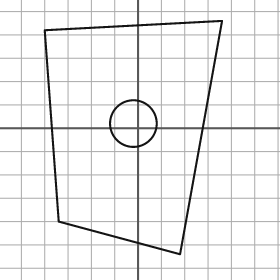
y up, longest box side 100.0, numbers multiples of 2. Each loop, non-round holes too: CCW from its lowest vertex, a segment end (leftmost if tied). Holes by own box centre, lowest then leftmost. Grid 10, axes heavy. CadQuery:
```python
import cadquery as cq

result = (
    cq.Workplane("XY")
    .moveTo(18.0, -54.0)
    .lineTo(36.0, 46.0)
    .lineTo(-40.0, 42.0)
    .lineTo(-34.0, -40.0)
    .close()
    .moveTo(-2.0, 2.0)
    .circle(10.0)
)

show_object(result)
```